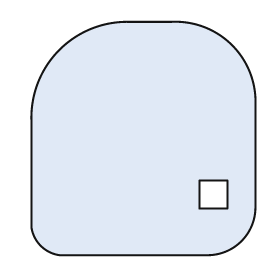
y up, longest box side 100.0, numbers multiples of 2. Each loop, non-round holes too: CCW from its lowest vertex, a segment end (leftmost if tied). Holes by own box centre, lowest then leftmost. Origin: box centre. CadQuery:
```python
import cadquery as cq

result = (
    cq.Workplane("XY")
    .moveTo(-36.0, -50.0)
    .lineTo(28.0, -50.0)
    .threePointArc((42.0, -44.0), (48.0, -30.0))
    .lineTo(48.0, 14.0)
    .threePointArc((38.0, 40.0), (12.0, 50.0))
    .lineTo(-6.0, 50.0)
    .threePointArc((-36.0, 38.0), (-48.0, 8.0))
    .lineTo(-48.0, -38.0)
    .threePointArc((-44.0, -46.0), (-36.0, -50.0))
    .close()
    .moveTo(24.0, -30.0)
    .lineTo(36.0, -30.0)
    .lineTo(36.0, -18.0)
    .lineTo(24.0, -18.0)
    .close()
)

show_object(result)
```